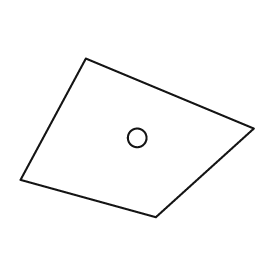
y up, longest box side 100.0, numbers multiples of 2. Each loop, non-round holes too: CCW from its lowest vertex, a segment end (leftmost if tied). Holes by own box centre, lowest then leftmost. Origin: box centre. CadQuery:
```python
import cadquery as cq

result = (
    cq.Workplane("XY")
    .moveTo(8.0, -34.0)
    .lineTo(50.0, 4.0)
    .lineTo(-22.0, 34.0)
    .lineTo(-50.0, -18.0)
    .close()
    .moveTo(0.0, 0.0)
    .circle(4.0)
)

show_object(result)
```